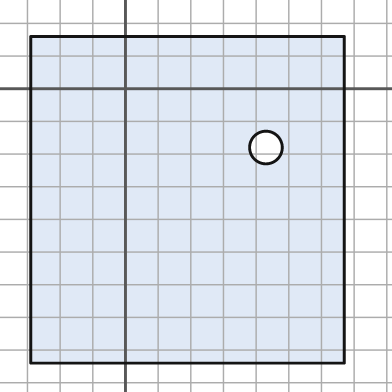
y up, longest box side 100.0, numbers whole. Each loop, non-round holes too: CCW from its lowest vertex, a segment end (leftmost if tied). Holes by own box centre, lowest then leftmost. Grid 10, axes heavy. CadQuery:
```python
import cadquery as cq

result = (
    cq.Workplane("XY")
    .moveTo(-29.0, -84.0)
    .lineTo(67.0, -84.0)
    .lineTo(67.0, 16.0)
    .lineTo(-29.0, 16.0)
    .close()
    .moveTo(43.0, -18.0)
    .circle(5.0)
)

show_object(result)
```